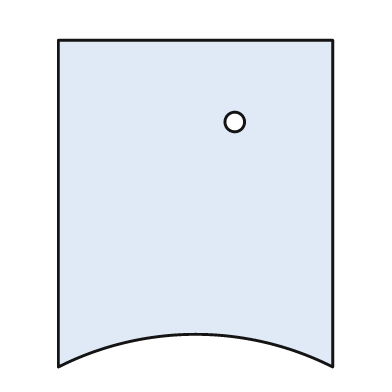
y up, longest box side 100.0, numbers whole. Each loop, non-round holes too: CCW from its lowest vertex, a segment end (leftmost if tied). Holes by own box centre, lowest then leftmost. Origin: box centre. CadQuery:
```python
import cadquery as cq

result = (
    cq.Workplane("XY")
    .moveTo(-42.0, -50.0)
    .threePointArc((0.0, -40.0), (42.0, -50.0))
    .lineTo(42.0, 50.0)
    .lineTo(-42.0, 50.0)
    .close()
    .moveTo(12.0, 25.0)
    .circle(3.0)
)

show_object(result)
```